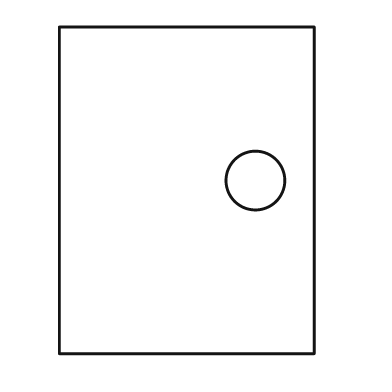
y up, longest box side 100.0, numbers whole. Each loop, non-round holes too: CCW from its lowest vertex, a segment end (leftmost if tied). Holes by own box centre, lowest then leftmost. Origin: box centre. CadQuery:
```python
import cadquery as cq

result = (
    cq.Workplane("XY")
    .moveTo(-39.0, -50.0)
    .lineTo(39.0, -50.0)
    .lineTo(39.0, 50.0)
    .lineTo(-39.0, 50.0)
    .close()
    .moveTo(21.0, 3.0)
    .circle(9.0)
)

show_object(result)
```